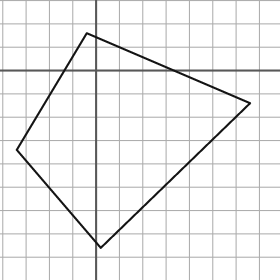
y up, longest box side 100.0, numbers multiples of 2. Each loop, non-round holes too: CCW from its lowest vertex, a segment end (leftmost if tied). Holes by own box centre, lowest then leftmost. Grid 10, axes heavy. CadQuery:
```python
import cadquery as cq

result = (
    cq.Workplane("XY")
    .moveTo(2.0, -76.0)
    .lineTo(66.0, -14.0)
    .lineTo(-4.0, 16.0)
    .lineTo(-34.0, -34.0)
    .close()
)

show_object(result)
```